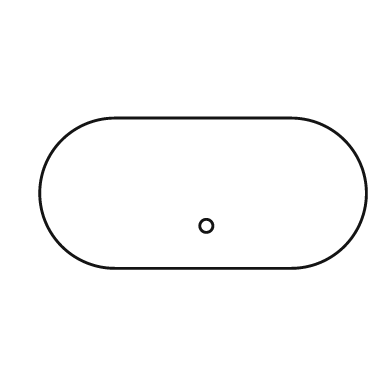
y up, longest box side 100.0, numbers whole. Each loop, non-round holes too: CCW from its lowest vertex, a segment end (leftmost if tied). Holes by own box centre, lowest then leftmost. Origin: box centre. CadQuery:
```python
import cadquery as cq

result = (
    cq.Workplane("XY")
    .moveTo(-27.0, -23.0)
    .lineTo(27.0, -23.0)
    .threePointArc((50.0, 0.0), (27.0, 23.0))
    .lineTo(-27.0, 23.0)
    .threePointArc((-50.0, 0.0), (-27.0, -23.0))
    .close()
    .moveTo(1.0, -10.0)
    .circle(2.0)
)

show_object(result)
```